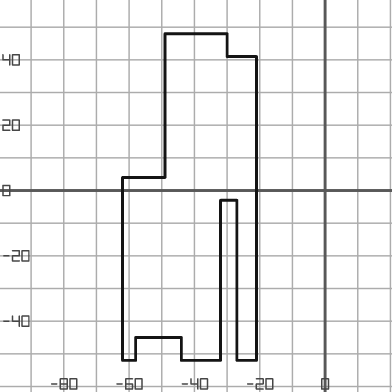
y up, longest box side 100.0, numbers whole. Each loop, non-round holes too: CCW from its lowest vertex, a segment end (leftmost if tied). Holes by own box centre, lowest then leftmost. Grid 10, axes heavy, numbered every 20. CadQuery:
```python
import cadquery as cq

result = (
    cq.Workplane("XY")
    .moveTo(-62.0, -52.0)
    .lineTo(-58.0, -52.0)
    .lineTo(-58.0, -45.0)
    .lineTo(-44.0, -45.0)
    .lineTo(-44.0, -52.0)
    .lineTo(-32.0, -52.0)
    .lineTo(-32.0, -3.0)
    .lineTo(-27.0, -3.0)
    .lineTo(-27.0, -52.0)
    .lineTo(-21.0, -52.0)
    .lineTo(-21.0, 41.0)
    .lineTo(-30.0, 41.0)
    .lineTo(-30.0, 48.0)
    .lineTo(-49.0, 48.0)
    .lineTo(-49.0, 4.0)
    .lineTo(-62.0, 4.0)
    .close()
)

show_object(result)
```